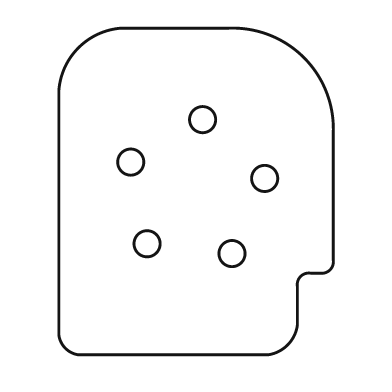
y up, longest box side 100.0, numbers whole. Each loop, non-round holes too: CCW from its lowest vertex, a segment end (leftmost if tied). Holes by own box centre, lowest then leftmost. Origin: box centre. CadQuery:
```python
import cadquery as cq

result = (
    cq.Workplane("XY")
    .moveTo(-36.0, -50.0)
    .lineTo(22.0, -50.0)
    .threePointArc((28.0, -47.0), (31.0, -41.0))
    .lineTo(31.0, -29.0)
    .threePointArc((32.0, -26.0), (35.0, -25.0))
    .lineTo(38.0, -25.0)
    .threePointArc((41.0, -24.0), (42.0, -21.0))
    .lineTo(42.0, 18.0)
    .threePointArc((33.0, 41.0), (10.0, 50.0))
    .lineTo(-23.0, 50.0)
    .threePointArc((-36.0, 44.0), (-42.0, 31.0))
    .lineTo(-42.0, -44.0)
    .threePointArc((-40.0, -48.0), (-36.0, -50.0))
    .close()
    .moveTo(11.0, -19.0)
    .circle(4.0)
    .moveTo(-15.0, -16.0)
    .circle(4.0)
    .moveTo(21.0, 4.0)
    .circle(4.0)
    .moveTo(-20.0, 9.0)
    .circle(4.0)
    .moveTo(2.0, 22.0)
    .circle(4.0)
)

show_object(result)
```